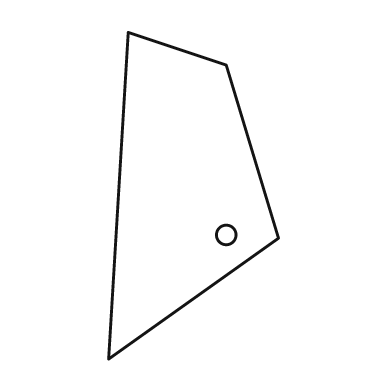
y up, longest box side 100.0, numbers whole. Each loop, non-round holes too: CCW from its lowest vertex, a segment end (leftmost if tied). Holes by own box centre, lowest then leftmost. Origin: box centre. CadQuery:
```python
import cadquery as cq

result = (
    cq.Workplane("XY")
    .moveTo(-26.0, -50.0)
    .lineTo(26.0, -13.0)
    .lineTo(10.0, 40.0)
    .lineTo(-20.0, 50.0)
    .close()
    .moveTo(10.0, -12.0)
    .circle(3.0)
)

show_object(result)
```